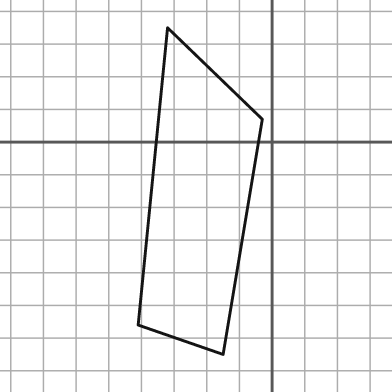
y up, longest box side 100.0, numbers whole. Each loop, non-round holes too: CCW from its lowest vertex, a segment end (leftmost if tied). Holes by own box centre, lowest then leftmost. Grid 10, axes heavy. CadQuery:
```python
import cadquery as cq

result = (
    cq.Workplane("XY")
    .moveTo(-15.0, -65.0)
    .lineTo(-3.0, 7.0)
    .lineTo(-32.0, 35.0)
    .lineTo(-41.0, -56.0)
    .close()
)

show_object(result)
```